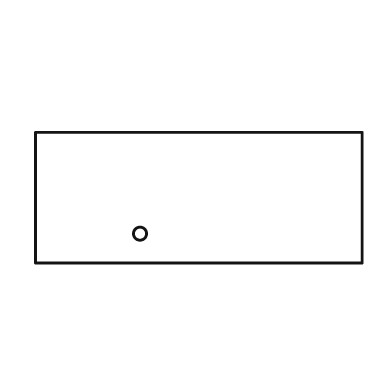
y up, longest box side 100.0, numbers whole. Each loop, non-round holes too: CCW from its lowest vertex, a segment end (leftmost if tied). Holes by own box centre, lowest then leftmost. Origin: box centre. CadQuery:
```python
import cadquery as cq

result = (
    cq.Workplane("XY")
    .moveTo(-50.0, -20.0)
    .lineTo(50.0, -20.0)
    .lineTo(50.0, 20.0)
    .lineTo(-50.0, 20.0)
    .close()
    .moveTo(-18.0, -11.0)
    .circle(2.0)
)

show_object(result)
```